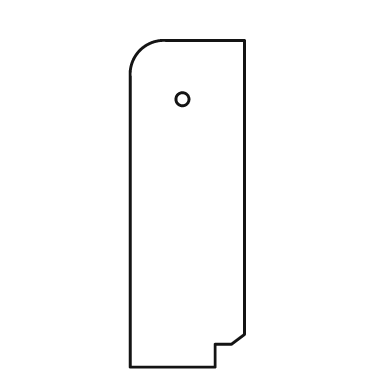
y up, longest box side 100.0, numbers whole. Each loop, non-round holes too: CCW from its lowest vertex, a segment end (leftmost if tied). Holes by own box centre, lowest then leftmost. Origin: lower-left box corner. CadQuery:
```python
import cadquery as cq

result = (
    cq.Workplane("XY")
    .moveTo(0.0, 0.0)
    .lineTo(26.0, 0.0)
    .lineTo(26.0, 7.0)
    .lineTo(31.0, 7.0)
    .lineTo(35.0, 10.0)
    .lineTo(35.0, 100.0)
    .lineTo(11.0, 100.0)
    .threePointArc((3.0, 97.0), (0.0, 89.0))
    .close()
    .moveTo(16.0, 82.0)
    .circle(2.0)
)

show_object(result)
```